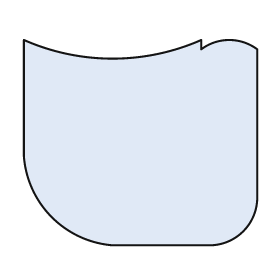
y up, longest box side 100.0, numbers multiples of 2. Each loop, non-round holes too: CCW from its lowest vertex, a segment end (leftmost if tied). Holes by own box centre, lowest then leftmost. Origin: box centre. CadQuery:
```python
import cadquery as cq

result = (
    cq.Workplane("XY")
    .moveTo(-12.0, -44.0)
    .lineTo(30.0, -44.0)
    .threePointArc((44.0, -38.0), (50.0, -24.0))
    .lineTo(50.0, 40.0)
    .threePointArc((38.0, 44.0), (26.0, 40.0))
    .lineTo(26.0, 44.0)
    .threePointArc((-12.0, 36.0), (-50.0, 44.0))
    .lineTo(-50.0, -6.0)
    .threePointArc((-38.0, -32.0), (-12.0, -44.0))
    .close()
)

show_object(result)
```